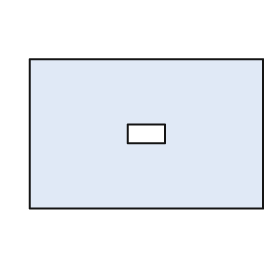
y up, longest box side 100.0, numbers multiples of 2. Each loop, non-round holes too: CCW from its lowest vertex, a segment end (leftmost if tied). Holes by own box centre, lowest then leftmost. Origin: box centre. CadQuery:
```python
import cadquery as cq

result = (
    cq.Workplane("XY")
    .moveTo(-50.0, -32.0)
    .lineTo(50.0, -32.0)
    .lineTo(50.0, 32.0)
    .lineTo(-50.0, 32.0)
    .close()
    .moveTo(-8.0, -4.0)
    .lineTo(8.0, -4.0)
    .lineTo(8.0, 4.0)
    .lineTo(-8.0, 4.0)
    .close()
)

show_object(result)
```